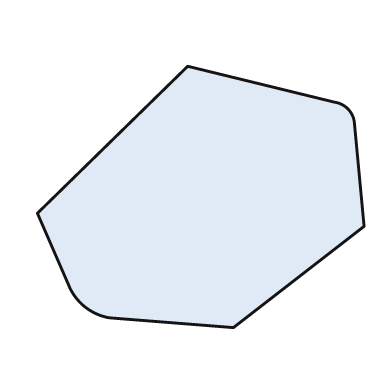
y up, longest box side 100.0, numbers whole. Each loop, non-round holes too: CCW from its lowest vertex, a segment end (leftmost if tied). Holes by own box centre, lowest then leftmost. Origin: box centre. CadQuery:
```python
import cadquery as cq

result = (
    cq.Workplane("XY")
    .moveTo(10.0, -40.0)
    .lineTo(50.0, -9.0)
    .lineTo(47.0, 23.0)
    .threePointArc((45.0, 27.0), (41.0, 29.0))
    .lineTo(-4.0, 40.0)
    .lineTo(-50.0, -5.0)
    .lineTo(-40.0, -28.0)
    .threePointArc((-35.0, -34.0), (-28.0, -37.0))
    .close()
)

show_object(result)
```